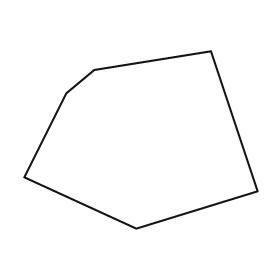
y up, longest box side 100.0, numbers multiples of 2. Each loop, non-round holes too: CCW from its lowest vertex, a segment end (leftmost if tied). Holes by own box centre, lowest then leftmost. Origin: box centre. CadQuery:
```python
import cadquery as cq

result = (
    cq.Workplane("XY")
    .moveTo(-2.0, -38.0)
    .lineTo(50.0, -22.0)
    .lineTo(30.0, 38.0)
    .lineTo(-20.0, 30.0)
    .lineTo(-32.0, 20.0)
    .lineTo(-50.0, -16.0)
    .close()
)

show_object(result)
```